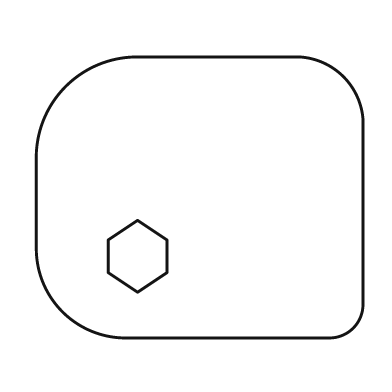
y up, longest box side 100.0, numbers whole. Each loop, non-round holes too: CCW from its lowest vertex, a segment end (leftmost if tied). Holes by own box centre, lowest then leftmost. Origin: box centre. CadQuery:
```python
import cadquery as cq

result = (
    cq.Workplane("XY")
    .moveTo(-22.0, -43.0)
    .lineTo(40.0, -43.0)
    .threePointArc((47.0, -40.0), (50.0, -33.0))
    .lineTo(50.0, 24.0)
    .threePointArc((44.0, 37.0), (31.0, 43.0))
    .lineTo(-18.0, 43.0)
    .threePointArc((-41.0, 34.0), (-50.0, 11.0))
    .lineTo(-50.0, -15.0)
    .threePointArc((-42.0, -35.0), (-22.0, -43.0))
    .close()
    .moveTo(-19.0, -29.0)
    .lineTo(-10.0, -23.0)
    .lineTo(-10.0, -13.0)
    .lineTo(-19.0, -7.0)
    .lineTo(-28.0, -13.0)
    .lineTo(-28.0, -23.0)
    .close()
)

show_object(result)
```